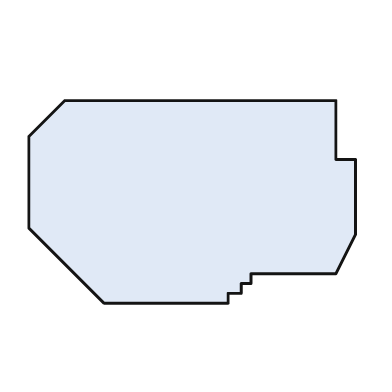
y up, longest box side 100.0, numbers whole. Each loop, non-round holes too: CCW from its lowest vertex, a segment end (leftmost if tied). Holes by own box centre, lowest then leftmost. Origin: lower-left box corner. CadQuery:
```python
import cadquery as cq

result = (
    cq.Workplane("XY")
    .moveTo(23.0, 0.0)
    .lineTo(61.0, 0.0)
    .lineTo(61.0, 3.0)
    .lineTo(65.0, 3.0)
    .lineTo(65.0, 6.0)
    .lineTo(68.0, 6.0)
    .lineTo(68.0, 9.0)
    .lineTo(94.0, 9.0)
    .lineTo(100.0, 21.0)
    .lineTo(100.0, 44.0)
    .lineTo(94.0, 44.0)
    .lineTo(94.0, 62.0)
    .lineTo(11.0, 62.0)
    .lineTo(0.0, 51.0)
    .lineTo(0.0, 23.0)
    .close()
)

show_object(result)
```